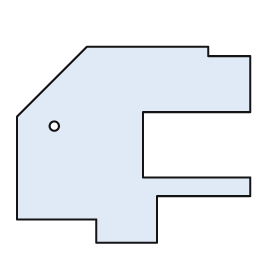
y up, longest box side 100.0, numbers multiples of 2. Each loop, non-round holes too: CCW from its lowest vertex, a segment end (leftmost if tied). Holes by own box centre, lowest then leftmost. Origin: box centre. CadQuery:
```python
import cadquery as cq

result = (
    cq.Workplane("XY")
    .moveTo(-16.0, -42.0)
    .lineTo(10.0, -42.0)
    .lineTo(10.0, -22.0)
    .lineTo(50.0, -22.0)
    .lineTo(50.0, -14.0)
    .lineTo(4.0, -14.0)
    .lineTo(4.0, 14.0)
    .lineTo(50.0, 14.0)
    .lineTo(50.0, 38.0)
    .lineTo(32.0, 38.0)
    .lineTo(32.0, 42.0)
    .lineTo(-20.0, 42.0)
    .lineTo(-50.0, 12.0)
    .lineTo(-50.0, -32.0)
    .lineTo(-16.0, -32.0)
    .close()
    .moveTo(-34.0, 8.0)
    .circle(2.0)
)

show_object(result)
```